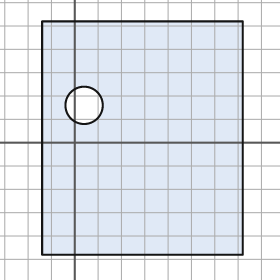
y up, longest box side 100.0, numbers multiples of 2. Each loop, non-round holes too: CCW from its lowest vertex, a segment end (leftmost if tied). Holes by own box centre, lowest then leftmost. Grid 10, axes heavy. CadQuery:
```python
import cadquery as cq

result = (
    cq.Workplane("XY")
    .moveTo(-14.0, -48.0)
    .lineTo(72.0, -48.0)
    .lineTo(72.0, 52.0)
    .lineTo(-14.0, 52.0)
    .close()
    .moveTo(4.0, 16.0)
    .circle(8.0)
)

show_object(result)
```